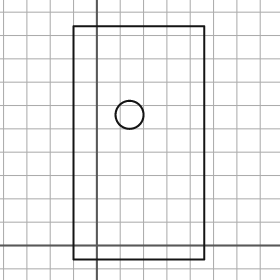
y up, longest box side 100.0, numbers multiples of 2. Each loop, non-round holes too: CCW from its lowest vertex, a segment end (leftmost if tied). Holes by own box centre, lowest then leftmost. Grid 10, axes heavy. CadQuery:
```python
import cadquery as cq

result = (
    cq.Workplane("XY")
    .moveTo(-10.0, -6.0)
    .lineTo(46.0, -6.0)
    .lineTo(46.0, 94.0)
    .lineTo(-10.0, 94.0)
    .close()
    .moveTo(14.0, 56.0)
    .circle(6.0)
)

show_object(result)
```